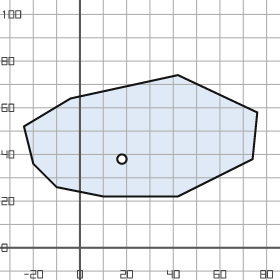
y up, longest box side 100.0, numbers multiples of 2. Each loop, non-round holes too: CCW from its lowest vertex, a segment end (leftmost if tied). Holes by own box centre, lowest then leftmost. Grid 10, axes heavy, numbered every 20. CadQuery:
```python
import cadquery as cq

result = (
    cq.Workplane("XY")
    .moveTo(10.0, 22.0)
    .lineTo(42.0, 22.0)
    .lineTo(74.0, 38.0)
    .lineTo(76.0, 58.0)
    .lineTo(42.0, 74.0)
    .lineTo(-4.0, 64.0)
    .lineTo(-24.0, 52.0)
    .lineTo(-20.0, 36.0)
    .lineTo(-10.0, 26.0)
    .close()
    .moveTo(18.0, 38.0)
    .circle(2.0)
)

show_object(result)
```